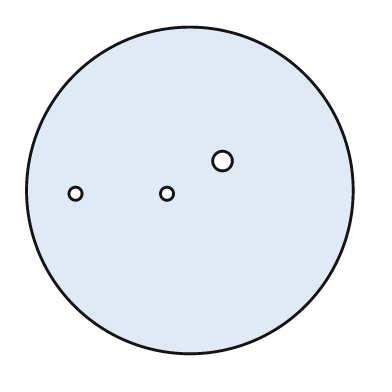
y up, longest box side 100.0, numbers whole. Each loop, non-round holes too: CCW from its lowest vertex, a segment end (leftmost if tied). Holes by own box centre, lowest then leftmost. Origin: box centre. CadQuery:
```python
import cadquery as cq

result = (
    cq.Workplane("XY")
    .moveTo(0.0, 0.0)
    .circle(50.0)
    .moveTo(-35.0, -1.0)
    .circle(2.0)
    .moveTo(-7.0, -1.0)
    .circle(2.0)
    .moveTo(10.0, 9.0)
    .circle(3.0)
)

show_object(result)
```